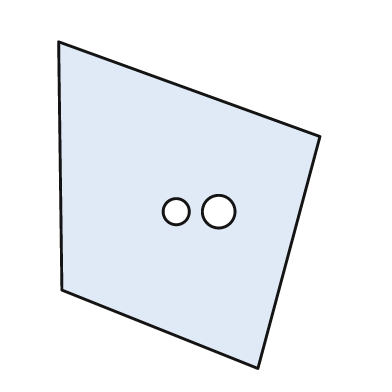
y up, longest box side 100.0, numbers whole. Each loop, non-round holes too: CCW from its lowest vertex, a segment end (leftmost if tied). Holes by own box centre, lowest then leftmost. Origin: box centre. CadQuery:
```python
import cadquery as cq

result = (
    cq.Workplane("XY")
    .moveTo(21.0, -50.0)
    .lineTo(40.0, 21.0)
    .lineTo(-40.0, 50.0)
    .lineTo(-39.0, -26.0)
    .close()
    .moveTo(-4.0, -2.0)
    .circle(4.0)
    .moveTo(9.0, -2.0)
    .circle(5.0)
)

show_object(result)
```